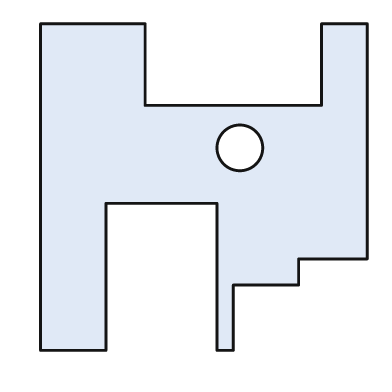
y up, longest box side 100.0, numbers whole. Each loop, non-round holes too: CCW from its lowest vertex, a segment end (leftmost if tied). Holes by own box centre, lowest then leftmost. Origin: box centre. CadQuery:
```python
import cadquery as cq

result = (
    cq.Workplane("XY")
    .moveTo(-50.0, -50.0)
    .lineTo(-30.0, -50.0)
    .lineTo(-30.0, -5.0)
    .lineTo(4.0, -5.0)
    .lineTo(4.0, -50.0)
    .lineTo(9.0, -50.0)
    .lineTo(9.0, -30.0)
    .lineTo(29.0, -30.0)
    .lineTo(29.0, -22.0)
    .lineTo(50.0, -22.0)
    .lineTo(50.0, 50.0)
    .lineTo(36.0, 50.0)
    .lineTo(36.0, 25.0)
    .lineTo(-18.0, 25.0)
    .lineTo(-18.0, 50.0)
    .lineTo(-50.0, 50.0)
    .close()
    .moveTo(11.0, 12.0)
    .circle(7.0)
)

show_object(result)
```